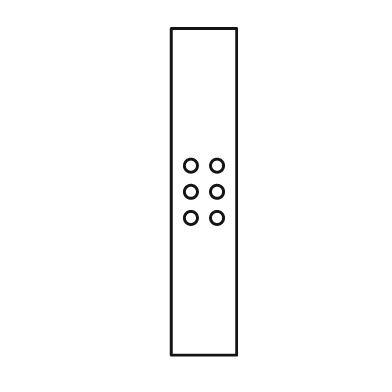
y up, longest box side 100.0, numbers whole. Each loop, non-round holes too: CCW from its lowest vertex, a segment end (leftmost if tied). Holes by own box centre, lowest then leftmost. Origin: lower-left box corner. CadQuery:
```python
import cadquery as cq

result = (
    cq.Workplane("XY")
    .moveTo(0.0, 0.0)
    .lineTo(20.0, 0.0)
    .lineTo(20.0, 100.0)
    .lineTo(0.0, 100.0)
    .close()
    .moveTo(6.0, 42.0)
    .circle(2.0)
    .moveTo(14.0, 42.0)
    .circle(2.0)
    .moveTo(6.0, 50.0)
    .circle(2.0)
    .moveTo(14.0, 50.0)
    .circle(2.0)
    .moveTo(6.0, 58.0)
    .circle(2.0)
    .moveTo(14.0, 58.0)
    .circle(2.0)
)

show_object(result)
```